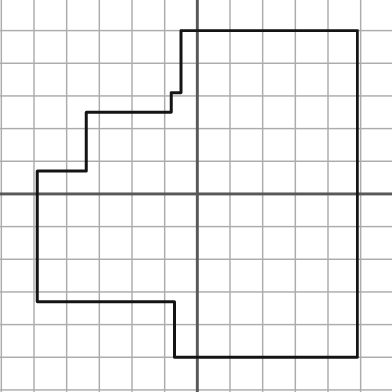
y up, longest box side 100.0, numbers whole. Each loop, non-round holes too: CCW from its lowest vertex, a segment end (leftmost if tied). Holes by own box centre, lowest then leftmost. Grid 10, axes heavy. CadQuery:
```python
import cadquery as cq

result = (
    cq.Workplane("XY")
    .moveTo(-7.0, -50.0)
    .lineTo(49.0, -50.0)
    .lineTo(49.0, 50.0)
    .lineTo(-5.0, 50.0)
    .lineTo(-5.0, 31.0)
    .lineTo(-8.0, 31.0)
    .lineTo(-8.0, 25.0)
    .lineTo(-34.0, 25.0)
    .lineTo(-34.0, 7.0)
    .lineTo(-49.0, 7.0)
    .lineTo(-49.0, -33.0)
    .lineTo(-7.0, -33.0)
    .close()
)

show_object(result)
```